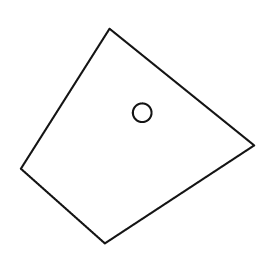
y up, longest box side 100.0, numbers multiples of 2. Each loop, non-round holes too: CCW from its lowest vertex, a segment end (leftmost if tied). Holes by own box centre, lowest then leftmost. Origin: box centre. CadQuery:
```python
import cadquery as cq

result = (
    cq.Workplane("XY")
    .moveTo(-14.0, -46.0)
    .lineTo(50.0, -4.0)
    .lineTo(-12.0, 46.0)
    .lineTo(-50.0, -14.0)
    .close()
    .moveTo(2.0, 10.0)
    .circle(4.0)
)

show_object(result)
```